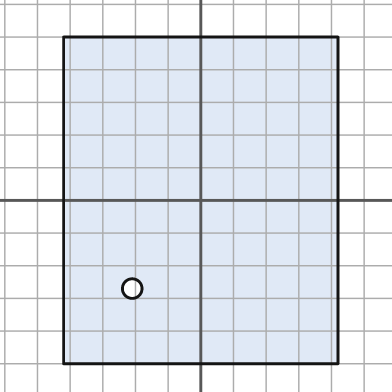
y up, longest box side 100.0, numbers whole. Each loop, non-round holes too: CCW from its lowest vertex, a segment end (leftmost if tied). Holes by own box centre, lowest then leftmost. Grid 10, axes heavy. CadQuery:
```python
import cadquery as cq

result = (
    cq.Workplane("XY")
    .moveTo(-42.0, -50.0)
    .lineTo(42.0, -50.0)
    .lineTo(42.0, 50.0)
    .lineTo(-42.0, 50.0)
    .close()
    .moveTo(-21.0, -27.0)
    .circle(3.0)
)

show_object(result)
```